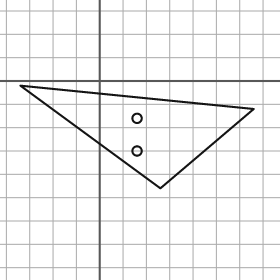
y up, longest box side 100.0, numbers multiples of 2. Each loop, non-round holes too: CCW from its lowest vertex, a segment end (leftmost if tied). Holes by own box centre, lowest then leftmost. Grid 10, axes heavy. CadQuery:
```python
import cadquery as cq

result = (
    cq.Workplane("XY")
    .moveTo(26.0, -46.0)
    .lineTo(66.0, -12.0)
    .lineTo(-34.0, -2.0)
    .close()
    .moveTo(16.0, -30.0)
    .circle(2.0)
    .moveTo(16.0, -16.0)
    .circle(2.0)
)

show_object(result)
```